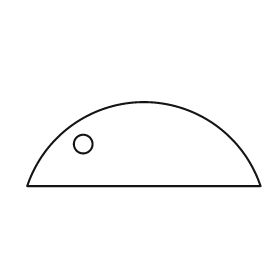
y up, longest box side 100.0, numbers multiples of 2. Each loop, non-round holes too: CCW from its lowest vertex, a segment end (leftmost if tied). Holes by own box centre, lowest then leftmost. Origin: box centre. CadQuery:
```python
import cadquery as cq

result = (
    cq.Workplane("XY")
    .moveTo(-50.0, -18.0)
    .lineTo(50.0, -18.0)
    .threePointArc((0.0, 18.0), (-50.0, -18.0))
    .close()
    .moveTo(-26.0, 0.0)
    .circle(4.0)
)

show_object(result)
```